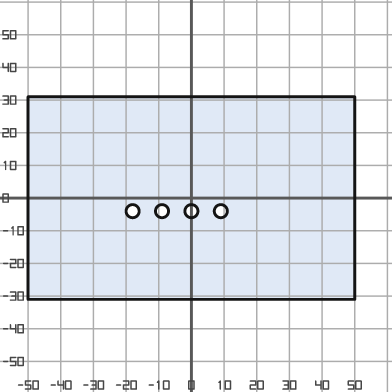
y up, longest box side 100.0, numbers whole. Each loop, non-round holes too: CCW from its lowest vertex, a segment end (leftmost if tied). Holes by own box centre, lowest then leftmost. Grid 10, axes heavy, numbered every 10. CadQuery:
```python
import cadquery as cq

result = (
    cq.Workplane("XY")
    .moveTo(-50.0, -31.0)
    .lineTo(50.0, -31.0)
    .lineTo(50.0, 31.0)
    .lineTo(-50.0, 31.0)
    .close()
    .moveTo(-18.0, -4.0)
    .circle(2.0)
    .moveTo(-9.0, -4.0)
    .circle(2.0)
    .moveTo(0.0, -4.0)
    .circle(2.0)
    .moveTo(9.0, -4.0)
    .circle(2.0)
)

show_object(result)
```